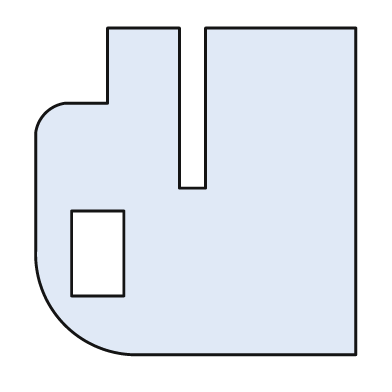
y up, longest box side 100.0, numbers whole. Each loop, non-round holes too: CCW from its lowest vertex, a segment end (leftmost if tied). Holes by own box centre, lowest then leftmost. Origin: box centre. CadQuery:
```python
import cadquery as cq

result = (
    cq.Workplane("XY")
    .moveTo(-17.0, -50.0)
    .lineTo(49.0, -50.0)
    .lineTo(49.0, 50.0)
    .lineTo(3.0, 50.0)
    .lineTo(3.0, 1.0)
    .lineTo(-5.0, 1.0)
    .lineTo(-5.0, 50.0)
    .lineTo(-27.0, 50.0)
    .lineTo(-27.0, 27.0)
    .lineTo(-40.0, 27.0)
    .threePointArc((-46.0, 24.0), (-49.0, 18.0))
    .lineTo(-49.0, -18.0)
    .threePointArc((-40.0, -41.0), (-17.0, -50.0))
    .close()
    .moveTo(-38.0, -32.0)
    .lineTo(-22.0, -32.0)
    .lineTo(-22.0, -6.0)
    .lineTo(-38.0, -6.0)
    .close()
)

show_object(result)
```